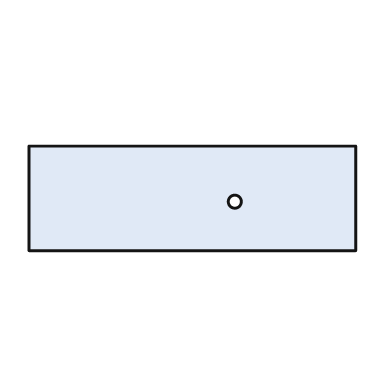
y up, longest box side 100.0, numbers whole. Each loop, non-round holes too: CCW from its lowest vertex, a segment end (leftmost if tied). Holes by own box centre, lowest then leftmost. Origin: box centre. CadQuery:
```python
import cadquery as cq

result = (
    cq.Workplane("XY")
    .moveTo(-50.0, -16.0)
    .lineTo(50.0, -16.0)
    .lineTo(50.0, 16.0)
    .lineTo(-50.0, 16.0)
    .close()
    .moveTo(13.0, -1.0)
    .circle(2.0)
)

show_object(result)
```